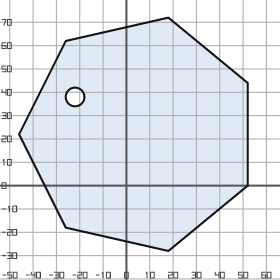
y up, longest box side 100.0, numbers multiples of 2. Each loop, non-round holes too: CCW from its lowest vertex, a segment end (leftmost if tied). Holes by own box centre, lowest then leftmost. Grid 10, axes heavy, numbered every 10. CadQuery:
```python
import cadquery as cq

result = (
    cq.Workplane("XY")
    .moveTo(18.0, -28.0)
    .lineTo(52.0, 0.0)
    .lineTo(52.0, 44.0)
    .lineTo(18.0, 72.0)
    .lineTo(-26.0, 62.0)
    .lineTo(-46.0, 22.0)
    .lineTo(-26.0, -18.0)
    .close()
    .moveTo(-22.0, 38.0)
    .circle(4.0)
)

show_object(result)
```